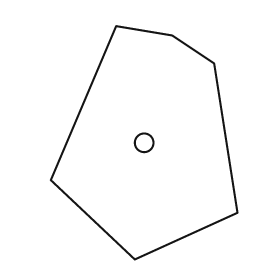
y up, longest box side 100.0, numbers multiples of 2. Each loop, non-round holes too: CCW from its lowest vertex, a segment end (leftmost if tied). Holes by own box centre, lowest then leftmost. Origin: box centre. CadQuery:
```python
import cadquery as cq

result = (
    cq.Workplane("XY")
    .moveTo(-4.0, -50.0)
    .lineTo(40.0, -30.0)
    .lineTo(30.0, 34.0)
    .lineTo(12.0, 46.0)
    .lineTo(-12.0, 50.0)
    .lineTo(-40.0, -16.0)
    .close()
    .moveTo(0.0, 0.0)
    .circle(4.0)
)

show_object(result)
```